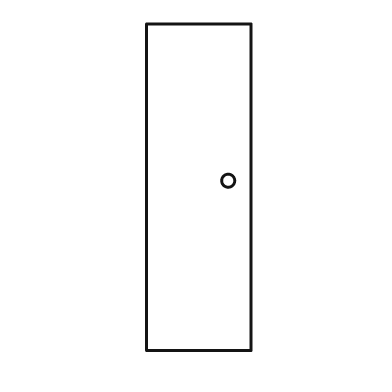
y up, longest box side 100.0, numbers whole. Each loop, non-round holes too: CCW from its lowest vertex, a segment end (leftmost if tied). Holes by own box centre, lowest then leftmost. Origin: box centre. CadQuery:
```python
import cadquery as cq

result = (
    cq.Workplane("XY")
    .moveTo(-16.0, -50.0)
    .lineTo(16.0, -50.0)
    .lineTo(16.0, 50.0)
    .lineTo(-16.0, 50.0)
    .close()
    .moveTo(9.0, 2.0)
    .circle(2.0)
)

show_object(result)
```